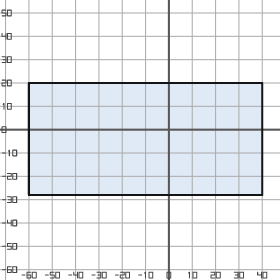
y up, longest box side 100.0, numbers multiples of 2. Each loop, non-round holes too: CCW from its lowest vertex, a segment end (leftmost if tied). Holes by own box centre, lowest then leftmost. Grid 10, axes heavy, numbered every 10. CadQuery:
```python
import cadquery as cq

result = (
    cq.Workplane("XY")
    .moveTo(-60.0, -28.0)
    .lineTo(40.0, -28.0)
    .lineTo(40.0, 20.0)
    .lineTo(-60.0, 20.0)
    .close()
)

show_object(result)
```